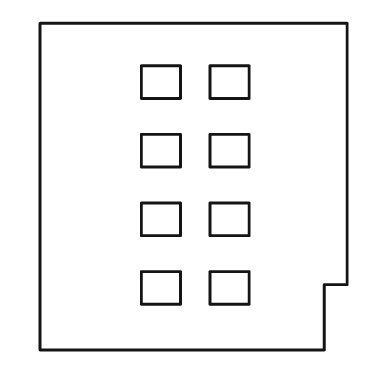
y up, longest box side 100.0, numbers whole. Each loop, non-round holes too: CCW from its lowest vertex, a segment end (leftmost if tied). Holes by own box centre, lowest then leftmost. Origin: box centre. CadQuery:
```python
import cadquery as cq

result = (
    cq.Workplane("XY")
    .moveTo(-47.0, -50.0)
    .lineTo(40.0, -50.0)
    .lineTo(40.0, -30.0)
    .lineTo(47.0, -30.0)
    .lineTo(47.0, 50.0)
    .lineTo(-47.0, 50.0)
    .close()
    .moveTo(-16.0, -36.0)
    .lineTo(-4.0, -36.0)
    .lineTo(-4.0, -26.0)
    .lineTo(-16.0, -26.0)
    .close()
    .moveTo(5.0, -36.0)
    .lineTo(17.0, -36.0)
    .lineTo(17.0, -26.0)
    .lineTo(5.0, -26.0)
    .close()
    .moveTo(-16.0, -15.0)
    .lineTo(-4.0, -15.0)
    .lineTo(-4.0, -5.0)
    .lineTo(-16.0, -5.0)
    .close()
    .moveTo(5.0, -15.0)
    .lineTo(17.0, -15.0)
    .lineTo(17.0, -5.0)
    .lineTo(5.0, -5.0)
    .close()
    .moveTo(-16.0, 6.0)
    .lineTo(-4.0, 6.0)
    .lineTo(-4.0, 16.0)
    .lineTo(-16.0, 16.0)
    .close()
    .moveTo(5.0, 6.0)
    .lineTo(17.0, 6.0)
    .lineTo(17.0, 16.0)
    .lineTo(5.0, 16.0)
    .close()
    .moveTo(-16.0, 27.0)
    .lineTo(-4.0, 27.0)
    .lineTo(-4.0, 37.0)
    .lineTo(-16.0, 37.0)
    .close()
    .moveTo(5.0, 27.0)
    .lineTo(17.0, 27.0)
    .lineTo(17.0, 37.0)
    .lineTo(5.0, 37.0)
    .close()
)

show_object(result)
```